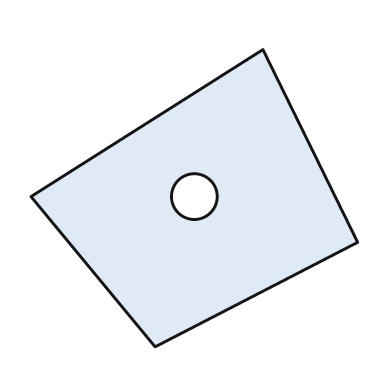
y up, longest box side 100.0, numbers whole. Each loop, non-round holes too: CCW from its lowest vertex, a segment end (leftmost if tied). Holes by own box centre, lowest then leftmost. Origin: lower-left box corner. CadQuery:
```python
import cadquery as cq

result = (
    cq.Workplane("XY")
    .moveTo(38.0, 0.0)
    .lineTo(100.0, 32.0)
    .lineTo(71.0, 91.0)
    .lineTo(0.0, 46.0)
    .close()
    .moveTo(50.0, 46.0)
    .circle(7.0)
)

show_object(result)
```